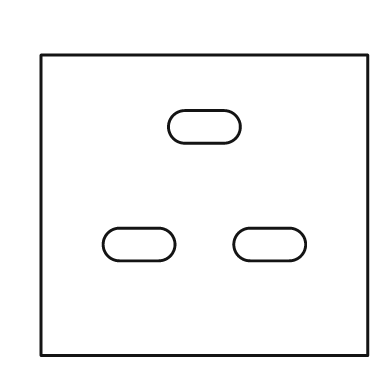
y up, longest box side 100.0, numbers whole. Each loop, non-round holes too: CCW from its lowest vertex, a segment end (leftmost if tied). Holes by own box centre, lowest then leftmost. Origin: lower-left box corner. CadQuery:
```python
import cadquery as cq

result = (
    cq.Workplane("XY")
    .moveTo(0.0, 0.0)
    .lineTo(100.0, 0.0)
    .lineTo(100.0, 92.0)
    .lineTo(0.0, 92.0)
    .close()
    .moveTo(24.0, 29.0)
    .lineTo(36.0, 29.0)
    .threePointArc((41.0, 34.0), (36.0, 39.0))
    .lineTo(24.0, 39.0)
    .threePointArc((19.0, 34.0), (24.0, 29.0))
    .close()
    .moveTo(64.0, 29.0)
    .lineTo(76.0, 29.0)
    .threePointArc((81.0, 34.0), (76.0, 39.0))
    .lineTo(64.0, 39.0)
    .threePointArc((59.0, 34.0), (64.0, 29.0))
    .close()
    .moveTo(44.0, 65.0)
    .lineTo(56.0, 65.0)
    .threePointArc((61.0, 70.0), (56.0, 75.0))
    .lineTo(44.0, 75.0)
    .threePointArc((39.0, 70.0), (44.0, 65.0))
    .close()
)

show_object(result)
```